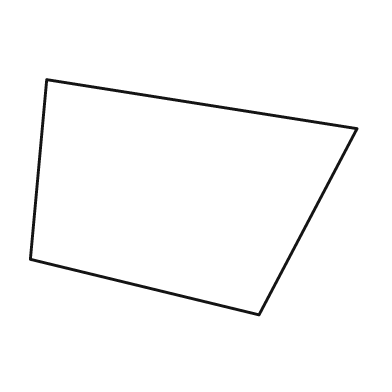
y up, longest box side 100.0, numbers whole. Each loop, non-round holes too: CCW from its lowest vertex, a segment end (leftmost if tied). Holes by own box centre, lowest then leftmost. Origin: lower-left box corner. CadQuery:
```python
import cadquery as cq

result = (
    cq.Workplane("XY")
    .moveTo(70.0, 0.0)
    .lineTo(100.0, 57.0)
    .lineTo(5.0, 72.0)
    .lineTo(0.0, 17.0)
    .close()
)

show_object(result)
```